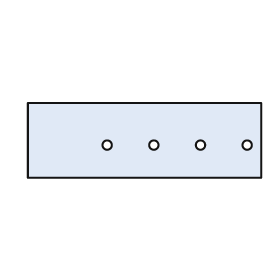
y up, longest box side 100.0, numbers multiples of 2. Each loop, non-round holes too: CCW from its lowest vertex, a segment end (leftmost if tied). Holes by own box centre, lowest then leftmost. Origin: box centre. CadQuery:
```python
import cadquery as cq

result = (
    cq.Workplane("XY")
    .moveTo(-50.0, -16.0)
    .lineTo(50.0, -16.0)
    .lineTo(50.0, 16.0)
    .lineTo(-50.0, 16.0)
    .close()
    .moveTo(-16.0, -2.0)
    .circle(2.0)
    .moveTo(4.0, -2.0)
    .circle(2.0)
    .moveTo(24.0, -2.0)
    .circle(2.0)
    .moveTo(44.0, -2.0)
    .circle(2.0)
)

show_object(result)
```